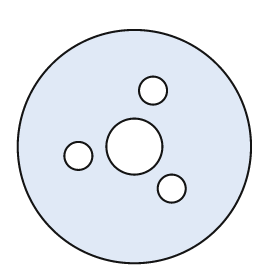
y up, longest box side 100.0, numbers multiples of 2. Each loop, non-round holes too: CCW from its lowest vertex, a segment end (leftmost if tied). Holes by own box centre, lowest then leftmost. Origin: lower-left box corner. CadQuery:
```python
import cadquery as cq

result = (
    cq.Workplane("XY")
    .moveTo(50.0, 50.0)
    .circle(50.0)
    .moveTo(66.0, 32.0)
    .circle(6.0)
    .moveTo(26.0, 46.0)
    .circle(6.0)
    .moveTo(50.0, 50.0)
    .circle(12.0)
    .moveTo(58.0, 74.0)
    .circle(6.0)
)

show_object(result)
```